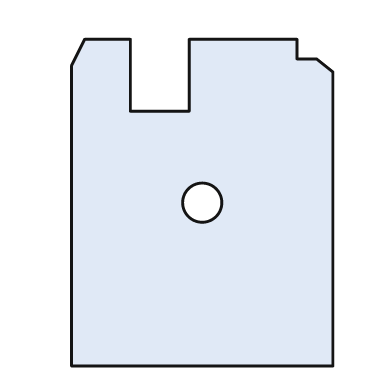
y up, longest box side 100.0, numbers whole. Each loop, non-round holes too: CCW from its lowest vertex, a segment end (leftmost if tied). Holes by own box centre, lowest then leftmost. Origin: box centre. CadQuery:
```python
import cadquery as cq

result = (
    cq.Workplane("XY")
    .moveTo(-40.0, -50.0)
    .lineTo(40.0, -50.0)
    .lineTo(40.0, 40.0)
    .lineTo(35.0, 44.0)
    .lineTo(29.0, 44.0)
    .lineTo(29.0, 50.0)
    .lineTo(-4.0, 50.0)
    .lineTo(-4.0, 28.0)
    .lineTo(-22.0, 28.0)
    .lineTo(-22.0, 50.0)
    .lineTo(-36.0, 50.0)
    .lineTo(-40.0, 42.0)
    .close()
    .moveTo(0.0, 0.0)
    .circle(6.0)
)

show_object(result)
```